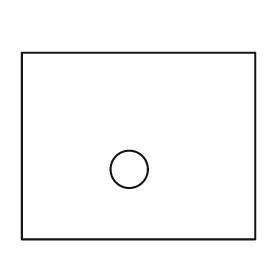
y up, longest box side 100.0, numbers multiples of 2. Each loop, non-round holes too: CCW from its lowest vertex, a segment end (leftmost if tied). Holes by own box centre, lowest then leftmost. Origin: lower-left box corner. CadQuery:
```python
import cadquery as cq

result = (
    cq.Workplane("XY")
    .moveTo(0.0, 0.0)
    .lineTo(100.0, 0.0)
    .lineTo(100.0, 80.0)
    .lineTo(0.0, 80.0)
    .close()
    .moveTo(46.0, 30.0)
    .circle(8.0)
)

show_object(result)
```